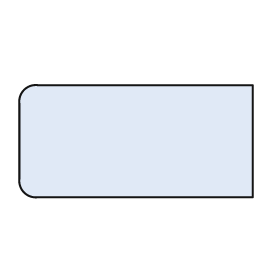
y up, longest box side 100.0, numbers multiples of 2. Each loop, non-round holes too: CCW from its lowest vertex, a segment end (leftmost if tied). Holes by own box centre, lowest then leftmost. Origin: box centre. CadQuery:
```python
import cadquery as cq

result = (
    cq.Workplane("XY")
    .moveTo(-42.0, -24.0)
    .lineTo(50.0, -24.0)
    .lineTo(50.0, 24.0)
    .lineTo(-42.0, 24.0)
    .threePointArc((-48.0, 22.0), (-50.0, 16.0))
    .lineTo(-50.0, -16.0)
    .threePointArc((-48.0, -22.0), (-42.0, -24.0))
    .close()
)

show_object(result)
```